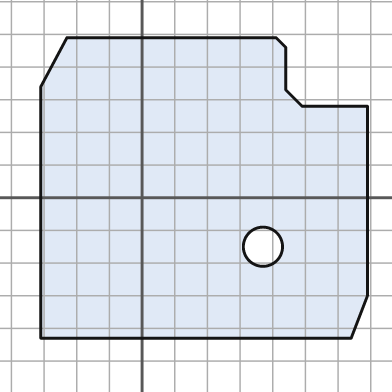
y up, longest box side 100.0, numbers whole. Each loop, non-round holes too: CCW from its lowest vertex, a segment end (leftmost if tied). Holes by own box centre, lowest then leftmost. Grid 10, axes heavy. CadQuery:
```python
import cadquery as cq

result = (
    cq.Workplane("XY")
    .moveTo(-31.0, -43.0)
    .lineTo(64.0, -43.0)
    .lineTo(69.0, -30.0)
    .lineTo(69.0, 28.0)
    .lineTo(49.0, 28.0)
    .lineTo(44.0, 33.0)
    .lineTo(44.0, 46.0)
    .lineTo(41.0, 49.0)
    .lineTo(-23.0, 49.0)
    .lineTo(-31.0, 34.0)
    .close()
    .moveTo(37.0, -15.0)
    .circle(6.0)
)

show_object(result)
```